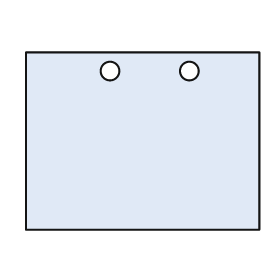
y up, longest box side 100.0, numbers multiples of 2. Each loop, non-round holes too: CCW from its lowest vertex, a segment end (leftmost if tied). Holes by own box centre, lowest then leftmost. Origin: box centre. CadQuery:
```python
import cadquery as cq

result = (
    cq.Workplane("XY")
    .moveTo(-50.0, -38.0)
    .lineTo(50.0, -38.0)
    .lineTo(50.0, 38.0)
    .lineTo(-50.0, 38.0)
    .close()
    .moveTo(-14.0, 30.0)
    .circle(4.0)
    .moveTo(20.0, 30.0)
    .circle(4.0)
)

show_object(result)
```